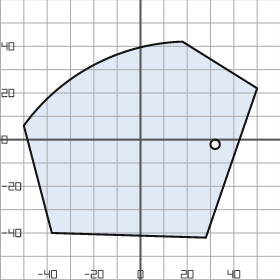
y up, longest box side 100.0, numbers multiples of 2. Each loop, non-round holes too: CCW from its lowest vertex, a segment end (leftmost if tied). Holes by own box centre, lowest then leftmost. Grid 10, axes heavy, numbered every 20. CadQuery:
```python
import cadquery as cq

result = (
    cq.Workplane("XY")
    .moveTo(28.0, -42.0)
    .lineTo(50.0, 22.0)
    .lineTo(18.0, 42.0)
    .threePointArc((-20.0, 32.0), (-50.0, 6.0))
    .lineTo(-38.0, -40.0)
    .close()
    .moveTo(32.0, -2.0)
    .circle(2.0)
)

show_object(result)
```